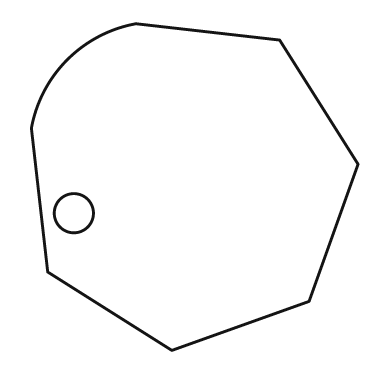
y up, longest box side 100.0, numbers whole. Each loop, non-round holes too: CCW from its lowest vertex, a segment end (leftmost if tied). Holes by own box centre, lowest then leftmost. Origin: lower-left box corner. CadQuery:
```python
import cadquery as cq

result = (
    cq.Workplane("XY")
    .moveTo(43.0, 0.0)
    .lineTo(85.0, 15.0)
    .lineTo(100.0, 57.0)
    .lineTo(76.0, 95.0)
    .lineTo(32.0, 100.0)
    .threePointArc((11.0, 89.0), (0.0, 68.0))
    .lineTo(5.0, 24.0)
    .close()
    .moveTo(13.0, 42.0)
    .circle(6.0)
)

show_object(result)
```